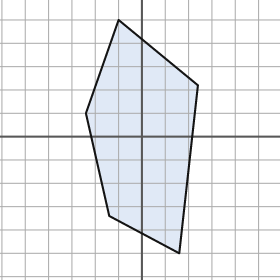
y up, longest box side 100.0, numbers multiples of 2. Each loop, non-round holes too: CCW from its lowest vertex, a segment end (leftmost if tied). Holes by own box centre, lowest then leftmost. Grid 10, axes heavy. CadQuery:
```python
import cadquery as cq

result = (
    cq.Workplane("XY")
    .moveTo(16.0, -50.0)
    .lineTo(24.0, 22.0)
    .lineTo(-10.0, 50.0)
    .lineTo(-24.0, 10.0)
    .lineTo(-14.0, -34.0)
    .close()
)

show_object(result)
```